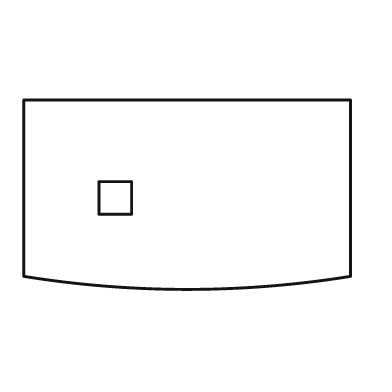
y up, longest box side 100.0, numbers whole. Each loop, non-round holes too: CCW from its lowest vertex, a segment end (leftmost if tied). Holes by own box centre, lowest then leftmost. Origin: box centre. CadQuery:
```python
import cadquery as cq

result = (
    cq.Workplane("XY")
    .moveTo(-50.0, -25.0)
    .threePointArc((0.0, -29.0), (50.0, -25.0))
    .lineTo(50.0, 29.0)
    .lineTo(-50.0, 29.0)
    .close()
    .moveTo(-27.0, -6.0)
    .lineTo(-17.0, -6.0)
    .lineTo(-17.0, 4.0)
    .lineTo(-27.0, 4.0)
    .close()
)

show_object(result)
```